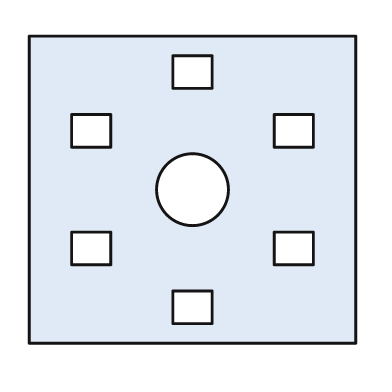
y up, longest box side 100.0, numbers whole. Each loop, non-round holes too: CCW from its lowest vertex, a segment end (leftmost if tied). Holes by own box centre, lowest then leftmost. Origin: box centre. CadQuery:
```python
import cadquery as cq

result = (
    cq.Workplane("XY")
    .moveTo(-50.0, -47.0)
    .lineTo(50.0, -47.0)
    .lineTo(50.0, 47.0)
    .lineTo(-50.0, 47.0)
    .close()
    .moveTo(-6.0, -41.0)
    .lineTo(6.0, -41.0)
    .lineTo(6.0, -31.0)
    .lineTo(-6.0, -31.0)
    .close()
    .moveTo(-37.0, -23.0)
    .lineTo(-25.0, -23.0)
    .lineTo(-25.0, -13.0)
    .lineTo(-37.0, -13.0)
    .close()
    .moveTo(25.0, -23.0)
    .lineTo(37.0, -23.0)
    .lineTo(37.0, -13.0)
    .lineTo(25.0, -13.0)
    .close()
    .moveTo(0.0, 0.0)
    .circle(11.0)
    .moveTo(-37.0, 13.0)
    .lineTo(-25.0, 13.0)
    .lineTo(-25.0, 23.0)
    .lineTo(-37.0, 23.0)
    .close()
    .moveTo(25.0, 13.0)
    .lineTo(37.0, 13.0)
    .lineTo(37.0, 23.0)
    .lineTo(25.0, 23.0)
    .close()
    .moveTo(-6.0, 31.0)
    .lineTo(6.0, 31.0)
    .lineTo(6.0, 41.0)
    .lineTo(-6.0, 41.0)
    .close()
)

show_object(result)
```